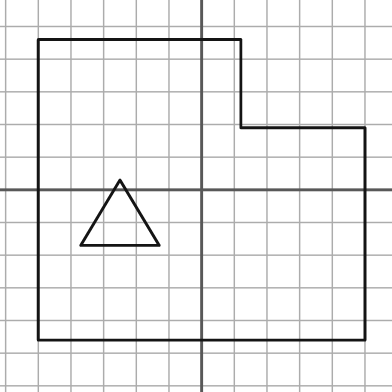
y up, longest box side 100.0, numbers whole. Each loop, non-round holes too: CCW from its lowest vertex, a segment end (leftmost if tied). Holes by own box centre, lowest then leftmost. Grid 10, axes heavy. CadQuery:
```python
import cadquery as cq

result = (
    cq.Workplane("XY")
    .moveTo(-50.0, -46.0)
    .lineTo(50.0, -46.0)
    .lineTo(50.0, 19.0)
    .lineTo(12.0, 19.0)
    .lineTo(12.0, 46.0)
    .lineTo(-50.0, 46.0)
    .close()
    .moveTo(-37.0, -17.0)
    .lineTo(-13.0, -17.0)
    .lineTo(-25.0, 3.0)
    .close()
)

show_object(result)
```